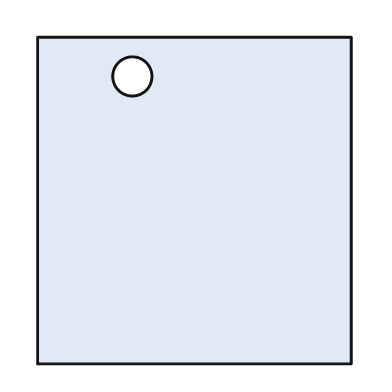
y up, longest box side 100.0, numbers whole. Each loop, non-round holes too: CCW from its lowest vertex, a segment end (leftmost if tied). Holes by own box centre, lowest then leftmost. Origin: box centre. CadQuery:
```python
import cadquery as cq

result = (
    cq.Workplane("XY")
    .moveTo(-48.0, -50.0)
    .lineTo(48.0, -50.0)
    .lineTo(48.0, 50.0)
    .lineTo(-48.0, 50.0)
    .close()
    .moveTo(-19.0, 38.0)
    .circle(6.0)
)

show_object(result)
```